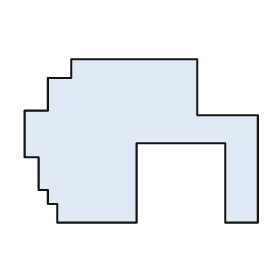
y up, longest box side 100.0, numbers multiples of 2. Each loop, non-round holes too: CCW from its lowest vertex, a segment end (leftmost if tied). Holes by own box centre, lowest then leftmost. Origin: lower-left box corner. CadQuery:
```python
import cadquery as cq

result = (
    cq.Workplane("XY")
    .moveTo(14.0, 0.0)
    .lineTo(48.0, 0.0)
    .lineTo(48.0, 34.0)
    .lineTo(86.0, 34.0)
    .lineTo(86.0, 0.0)
    .lineTo(100.0, 0.0)
    .lineTo(100.0, 46.0)
    .lineTo(74.0, 46.0)
    .lineTo(74.0, 70.0)
    .lineTo(20.0, 70.0)
    .lineTo(20.0, 62.0)
    .lineTo(10.0, 62.0)
    .lineTo(10.0, 48.0)
    .lineTo(0.0, 48.0)
    .lineTo(0.0, 28.0)
    .lineTo(6.0, 28.0)
    .lineTo(6.0, 14.0)
    .lineTo(10.0, 14.0)
    .lineTo(10.0, 8.0)
    .lineTo(14.0, 8.0)
    .close()
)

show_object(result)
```